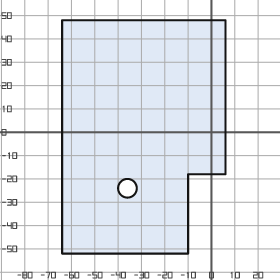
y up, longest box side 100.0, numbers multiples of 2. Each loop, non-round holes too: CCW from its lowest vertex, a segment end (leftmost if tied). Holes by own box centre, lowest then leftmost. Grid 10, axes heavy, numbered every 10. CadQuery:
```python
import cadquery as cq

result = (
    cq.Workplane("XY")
    .moveTo(-64.0, -52.0)
    .lineTo(-10.0, -52.0)
    .lineTo(-10.0, -18.0)
    .lineTo(6.0, -18.0)
    .lineTo(6.0, 48.0)
    .lineTo(-64.0, 48.0)
    .close()
    .moveTo(-36.0, -24.0)
    .circle(4.0)
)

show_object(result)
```